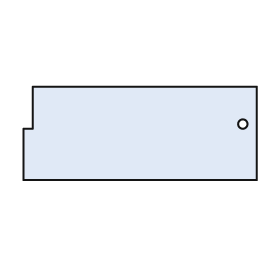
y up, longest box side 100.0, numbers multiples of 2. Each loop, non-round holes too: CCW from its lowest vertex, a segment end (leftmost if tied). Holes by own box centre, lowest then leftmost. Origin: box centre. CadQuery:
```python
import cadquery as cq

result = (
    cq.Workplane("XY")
    .moveTo(-50.0, -20.0)
    .lineTo(50.0, -20.0)
    .lineTo(50.0, 20.0)
    .lineTo(-46.0, 20.0)
    .lineTo(-46.0, 2.0)
    .lineTo(-50.0, 2.0)
    .close()
    .moveTo(44.0, 4.0)
    .circle(2.0)
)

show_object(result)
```